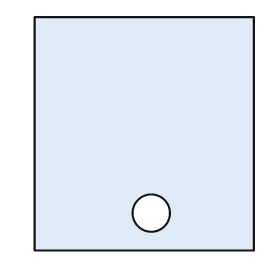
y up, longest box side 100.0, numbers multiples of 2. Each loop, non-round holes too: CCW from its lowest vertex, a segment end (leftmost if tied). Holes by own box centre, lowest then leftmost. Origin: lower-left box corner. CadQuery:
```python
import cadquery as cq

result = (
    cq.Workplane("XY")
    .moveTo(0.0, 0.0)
    .lineTo(94.0, 0.0)
    .lineTo(94.0, 100.0)
    .lineTo(0.0, 100.0)
    .close()
    .moveTo(50.0, 16.0)
    .circle(8.0)
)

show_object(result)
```